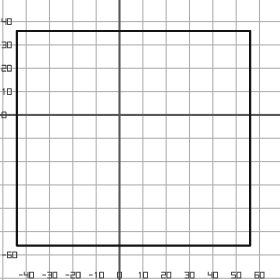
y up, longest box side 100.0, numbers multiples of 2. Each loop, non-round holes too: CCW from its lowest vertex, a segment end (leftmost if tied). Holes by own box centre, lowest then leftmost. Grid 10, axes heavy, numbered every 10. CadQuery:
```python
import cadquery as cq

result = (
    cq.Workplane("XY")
    .moveTo(-44.0, -56.0)
    .lineTo(56.0, -56.0)
    .lineTo(56.0, 36.0)
    .lineTo(-44.0, 36.0)
    .close()
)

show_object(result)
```